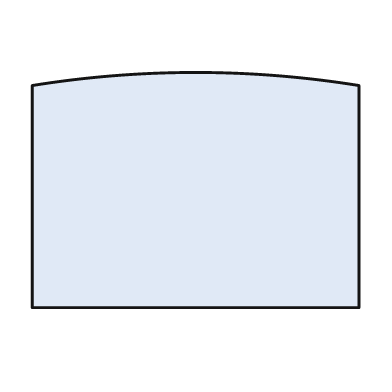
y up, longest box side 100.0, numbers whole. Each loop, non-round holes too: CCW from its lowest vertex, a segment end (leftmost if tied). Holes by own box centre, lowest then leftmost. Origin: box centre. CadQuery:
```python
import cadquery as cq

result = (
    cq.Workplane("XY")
    .moveTo(-50.0, -36.0)
    .lineTo(50.0, -36.0)
    .lineTo(50.0, 32.0)
    .threePointArc((0.0, 36.0), (-50.0, 32.0))
    .close()
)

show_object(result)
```